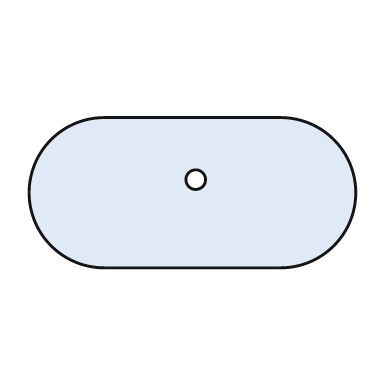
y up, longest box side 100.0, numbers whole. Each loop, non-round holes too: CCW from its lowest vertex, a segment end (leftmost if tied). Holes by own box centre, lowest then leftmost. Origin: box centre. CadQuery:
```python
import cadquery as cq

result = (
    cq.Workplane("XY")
    .moveTo(-27.0, -23.0)
    .lineTo(27.0, -23.0)
    .threePointArc((50.0, 0.0), (27.0, 23.0))
    .lineTo(-27.0, 23.0)
    .threePointArc((-50.0, 0.0), (-27.0, -23.0))
    .close()
    .moveTo(1.0, 4.0)
    .circle(3.0)
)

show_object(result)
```